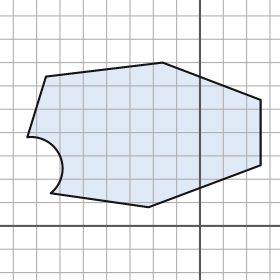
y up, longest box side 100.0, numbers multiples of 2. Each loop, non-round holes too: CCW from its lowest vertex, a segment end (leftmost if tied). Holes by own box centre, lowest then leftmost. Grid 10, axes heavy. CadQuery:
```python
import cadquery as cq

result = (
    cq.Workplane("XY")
    .moveTo(-22.0, 8.0)
    .lineTo(26.0, 26.0)
    .lineTo(26.0, 54.0)
    .lineTo(-16.0, 70.0)
    .lineTo(-66.0, 64.0)
    .lineTo(-74.0, 38.0)
    .threePointArc((-60.0, 30.0), (-64.0, 14.0))
    .close()
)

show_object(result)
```